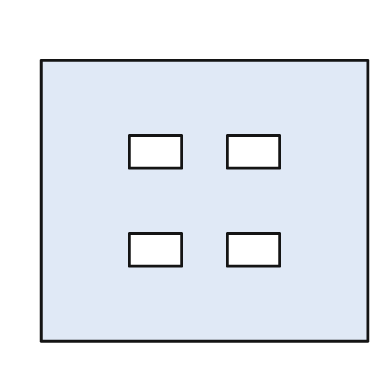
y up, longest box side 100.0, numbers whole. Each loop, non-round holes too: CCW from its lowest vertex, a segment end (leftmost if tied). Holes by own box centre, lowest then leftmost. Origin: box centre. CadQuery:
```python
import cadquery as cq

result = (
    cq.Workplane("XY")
    .moveTo(-50.0, -43.0)
    .lineTo(50.0, -43.0)
    .lineTo(50.0, 43.0)
    .lineTo(-50.0, 43.0)
    .close()
    .moveTo(-23.0, -20.0)
    .lineTo(-7.0, -20.0)
    .lineTo(-7.0, -10.0)
    .lineTo(-23.0, -10.0)
    .close()
    .moveTo(7.0, -20.0)
    .lineTo(23.0, -20.0)
    .lineTo(23.0, -10.0)
    .lineTo(7.0, -10.0)
    .close()
    .moveTo(-23.0, 10.0)
    .lineTo(-7.0, 10.0)
    .lineTo(-7.0, 20.0)
    .lineTo(-23.0, 20.0)
    .close()
    .moveTo(7.0, 10.0)
    .lineTo(23.0, 10.0)
    .lineTo(23.0, 20.0)
    .lineTo(7.0, 20.0)
    .close()
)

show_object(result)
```